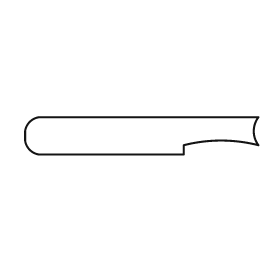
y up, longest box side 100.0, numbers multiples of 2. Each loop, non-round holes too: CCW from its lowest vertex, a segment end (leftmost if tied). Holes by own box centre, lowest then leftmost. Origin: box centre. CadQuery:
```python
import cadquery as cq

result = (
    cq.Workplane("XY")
    .moveTo(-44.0, -8.0)
    .lineTo(18.0, -8.0)
    .lineTo(18.0, -4.0)
    .threePointArc((34.0, -2.0), (50.0, -4.0))
    .threePointArc((48.0, 2.0), (50.0, 8.0))
    .lineTo(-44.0, 8.0)
    .threePointArc((-48.0, 6.0), (-50.0, 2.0))
    .lineTo(-50.0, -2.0)
    .threePointArc((-48.0, -6.0), (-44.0, -8.0))
    .close()
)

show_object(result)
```